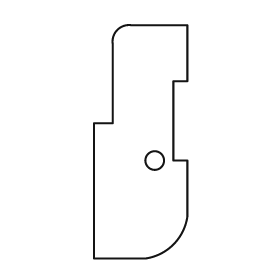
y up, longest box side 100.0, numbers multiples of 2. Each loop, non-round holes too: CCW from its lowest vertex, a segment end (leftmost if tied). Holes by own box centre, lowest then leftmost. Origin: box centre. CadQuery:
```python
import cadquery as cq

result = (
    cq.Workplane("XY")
    .moveTo(-20.0, -50.0)
    .lineTo(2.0, -50.0)
    .threePointArc((14.0, -44.0), (20.0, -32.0))
    .lineTo(20.0, -8.0)
    .lineTo(14.0, -8.0)
    .lineTo(14.0, 26.0)
    .lineTo(20.0, 26.0)
    .lineTo(20.0, 50.0)
    .lineTo(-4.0, 50.0)
    .threePointArc((-10.0, 48.0), (-12.0, 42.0))
    .lineTo(-12.0, 8.0)
    .lineTo(-20.0, 8.0)
    .close()
    .moveTo(6.0, -8.0)
    .circle(4.0)
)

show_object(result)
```